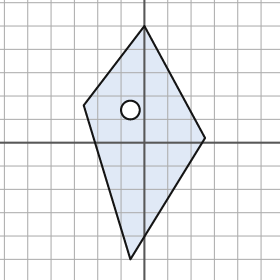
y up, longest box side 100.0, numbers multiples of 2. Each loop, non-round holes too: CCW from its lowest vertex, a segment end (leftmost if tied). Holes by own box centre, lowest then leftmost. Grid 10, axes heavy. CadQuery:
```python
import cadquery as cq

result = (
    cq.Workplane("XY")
    .moveTo(-6.0, -50.0)
    .lineTo(26.0, 2.0)
    .lineTo(0.0, 50.0)
    .lineTo(-26.0, 16.0)
    .close()
    .moveTo(-6.0, 14.0)
    .circle(4.0)
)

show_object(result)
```